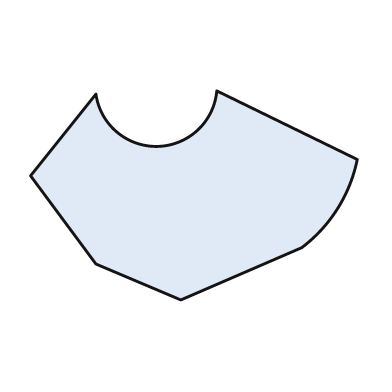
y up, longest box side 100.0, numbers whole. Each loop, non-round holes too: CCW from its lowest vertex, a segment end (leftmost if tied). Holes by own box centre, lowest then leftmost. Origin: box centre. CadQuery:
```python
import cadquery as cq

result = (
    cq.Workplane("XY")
    .moveTo(-4.0, -32.0)
    .lineTo(33.0, -16.0)
    .threePointArc((44.0, -4.0), (50.0, 11.0))
    .lineTo(7.0, 32.0)
    .threePointArc((-11.0, 15.0), (-30.0, 31.0))
    .lineTo(-50.0, 6.0)
    .lineTo(-30.0, -21.0)
    .close()
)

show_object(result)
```